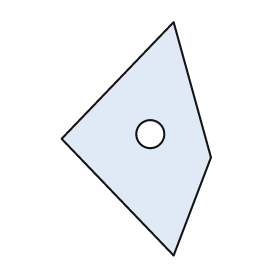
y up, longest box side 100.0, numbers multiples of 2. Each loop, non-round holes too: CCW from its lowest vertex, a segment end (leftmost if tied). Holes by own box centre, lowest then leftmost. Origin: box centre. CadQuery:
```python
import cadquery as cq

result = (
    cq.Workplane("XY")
    .moveTo(16.0, -50.0)
    .lineTo(32.0, -8.0)
    .lineTo(16.0, 50.0)
    .lineTo(-32.0, 0.0)
    .close()
    .moveTo(6.0, 2.0)
    .circle(6.0)
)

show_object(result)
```